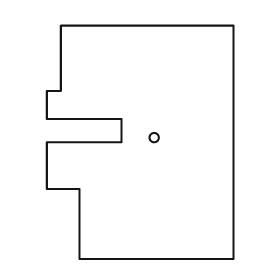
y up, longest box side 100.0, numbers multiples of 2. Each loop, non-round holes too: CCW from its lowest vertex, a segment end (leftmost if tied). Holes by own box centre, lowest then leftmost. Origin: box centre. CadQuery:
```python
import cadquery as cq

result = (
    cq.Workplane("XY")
    .moveTo(-26.0, -50.0)
    .lineTo(40.0, -50.0)
    .lineTo(40.0, 50.0)
    .lineTo(-34.0, 50.0)
    .lineTo(-34.0, 22.0)
    .lineTo(-40.0, 22.0)
    .lineTo(-40.0, 10.0)
    .lineTo(-8.0, 10.0)
    .lineTo(-8.0, 0.0)
    .lineTo(-40.0, 0.0)
    .lineTo(-40.0, -20.0)
    .lineTo(-26.0, -20.0)
    .close()
    .moveTo(6.0, 2.0)
    .circle(2.0)
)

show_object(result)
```